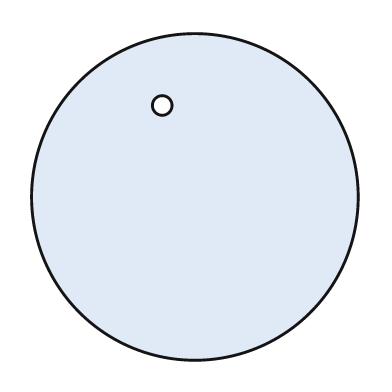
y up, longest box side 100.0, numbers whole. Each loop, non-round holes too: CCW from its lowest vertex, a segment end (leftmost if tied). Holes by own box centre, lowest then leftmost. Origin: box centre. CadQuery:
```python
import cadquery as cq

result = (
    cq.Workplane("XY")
    .moveTo(0.0, 0.0)
    .circle(50.0)
    .moveTo(-10.0, 28.0)
    .circle(3.0)
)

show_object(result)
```